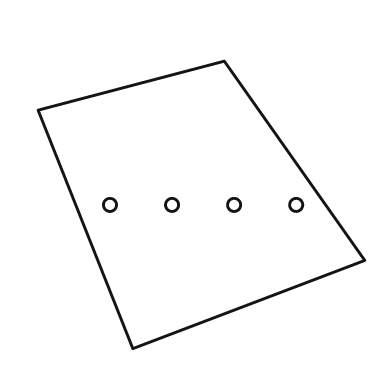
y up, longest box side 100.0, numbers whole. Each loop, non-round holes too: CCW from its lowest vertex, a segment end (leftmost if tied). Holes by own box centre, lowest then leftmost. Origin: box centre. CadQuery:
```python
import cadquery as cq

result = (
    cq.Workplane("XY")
    .moveTo(-21.0, -44.0)
    .lineTo(50.0, -17.0)
    .lineTo(7.0, 44.0)
    .lineTo(-50.0, 29.0)
    .close()
    .moveTo(-28.0, 0.0)
    .circle(2.0)
    .moveTo(-9.0, 0.0)
    .circle(2.0)
    .moveTo(10.0, 0.0)
    .circle(2.0)
    .moveTo(29.0, 0.0)
    .circle(2.0)
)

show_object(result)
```